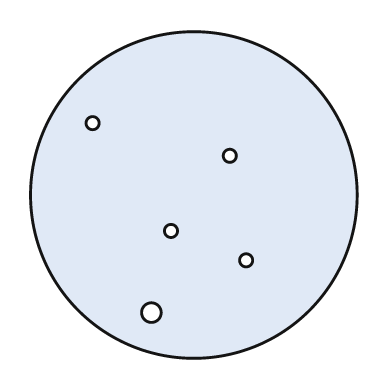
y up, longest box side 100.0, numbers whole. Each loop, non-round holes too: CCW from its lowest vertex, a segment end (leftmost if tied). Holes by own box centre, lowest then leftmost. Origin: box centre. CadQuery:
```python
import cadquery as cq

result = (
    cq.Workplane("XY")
    .moveTo(0.0, 0.0)
    .circle(50.0)
    .moveTo(-13.0, -36.0)
    .circle(3.0)
    .moveTo(16.0, -20.0)
    .circle(2.0)
    .moveTo(-7.0, -11.0)
    .circle(2.0)
    .moveTo(11.0, 12.0)
    .circle(2.0)
    .moveTo(-31.0, 22.0)
    .circle(2.0)
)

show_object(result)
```